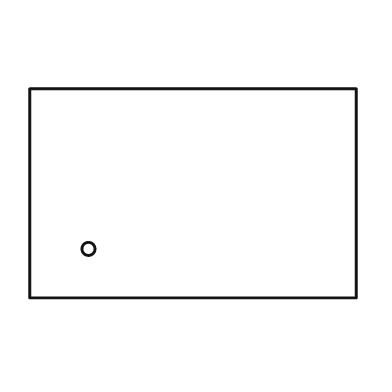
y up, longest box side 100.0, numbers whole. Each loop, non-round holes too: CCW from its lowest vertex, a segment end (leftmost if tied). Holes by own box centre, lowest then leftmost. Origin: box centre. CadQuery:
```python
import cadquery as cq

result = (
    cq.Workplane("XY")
    .moveTo(-50.0, -32.0)
    .lineTo(50.0, -32.0)
    .lineTo(50.0, 32.0)
    .lineTo(-50.0, 32.0)
    .close()
    .moveTo(-32.0, -17.0)
    .circle(2.0)
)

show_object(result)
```